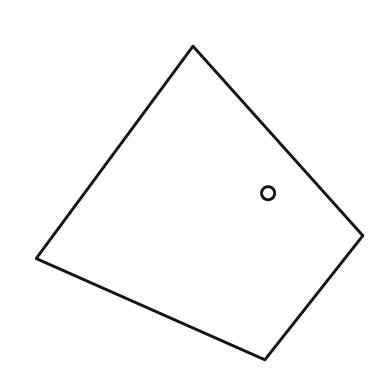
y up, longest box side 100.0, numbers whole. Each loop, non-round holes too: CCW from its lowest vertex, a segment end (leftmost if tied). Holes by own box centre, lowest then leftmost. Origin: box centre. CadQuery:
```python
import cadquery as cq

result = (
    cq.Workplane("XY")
    .moveTo(20.0, -48.0)
    .lineTo(50.0, -10.0)
    .lineTo(-2.0, 48.0)
    .lineTo(-50.0, -17.0)
    .close()
    .moveTo(21.0, 3.0)
    .circle(2.0)
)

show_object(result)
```